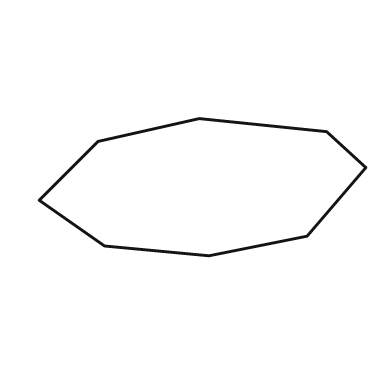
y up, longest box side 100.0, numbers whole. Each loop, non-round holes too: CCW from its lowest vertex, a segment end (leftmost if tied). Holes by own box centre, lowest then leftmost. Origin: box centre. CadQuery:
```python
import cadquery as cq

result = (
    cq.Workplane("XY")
    .moveTo(2.0, -21.0)
    .lineTo(32.0, -15.0)
    .lineTo(50.0, 6.0)
    .lineTo(38.0, 17.0)
    .lineTo(-1.0, 21.0)
    .lineTo(-32.0, 14.0)
    .lineTo(-50.0, -4.0)
    .lineTo(-30.0, -18.0)
    .close()
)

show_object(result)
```